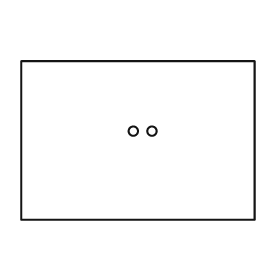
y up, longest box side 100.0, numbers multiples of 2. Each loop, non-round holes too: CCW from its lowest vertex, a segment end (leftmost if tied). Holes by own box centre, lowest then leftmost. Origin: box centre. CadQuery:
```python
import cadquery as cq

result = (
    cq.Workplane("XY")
    .moveTo(-50.0, -34.0)
    .lineTo(50.0, -34.0)
    .lineTo(50.0, 34.0)
    .lineTo(-50.0, 34.0)
    .close()
    .moveTo(-2.0, 4.0)
    .circle(2.0)
    .moveTo(6.0, 4.0)
    .circle(2.0)
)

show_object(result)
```